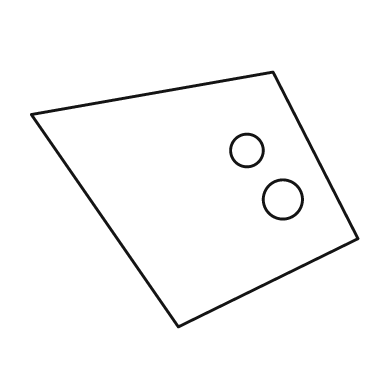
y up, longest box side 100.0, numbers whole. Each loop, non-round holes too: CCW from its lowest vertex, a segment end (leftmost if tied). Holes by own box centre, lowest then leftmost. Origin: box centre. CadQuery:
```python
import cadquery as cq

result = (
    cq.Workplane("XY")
    .moveTo(-5.0, -39.0)
    .lineTo(50.0, -12.0)
    .lineTo(24.0, 39.0)
    .lineTo(-50.0, 26.0)
    .close()
    .moveTo(27.0, 0.0)
    .circle(6.0)
    .moveTo(16.0, 15.0)
    .circle(5.0)
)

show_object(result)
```